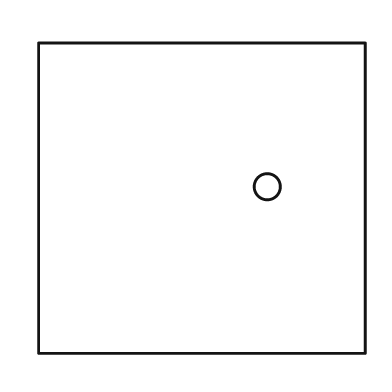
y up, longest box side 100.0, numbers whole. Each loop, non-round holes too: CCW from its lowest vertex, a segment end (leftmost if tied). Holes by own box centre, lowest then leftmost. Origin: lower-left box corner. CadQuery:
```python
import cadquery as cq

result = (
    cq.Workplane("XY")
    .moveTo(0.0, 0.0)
    .lineTo(100.0, 0.0)
    .lineTo(100.0, 95.0)
    .lineTo(0.0, 95.0)
    .close()
    .moveTo(70.0, 51.0)
    .circle(4.0)
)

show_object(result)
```